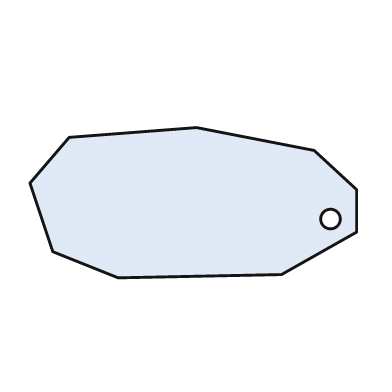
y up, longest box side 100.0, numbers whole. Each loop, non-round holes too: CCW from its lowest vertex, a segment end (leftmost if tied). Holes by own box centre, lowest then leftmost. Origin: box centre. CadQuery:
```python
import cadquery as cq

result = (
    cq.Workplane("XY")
    .moveTo(-23.0, -23.0)
    .lineTo(27.0, -22.0)
    .lineTo(50.0, -9.0)
    .lineTo(50.0, 4.0)
    .lineTo(37.0, 16.0)
    .lineTo(1.0, 23.0)
    .lineTo(-38.0, 20.0)
    .lineTo(-50.0, 6.0)
    .lineTo(-43.0, -15.0)
    .close()
    .moveTo(42.0, -5.0)
    .circle(3.0)
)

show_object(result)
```